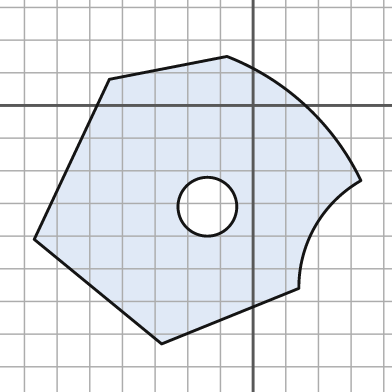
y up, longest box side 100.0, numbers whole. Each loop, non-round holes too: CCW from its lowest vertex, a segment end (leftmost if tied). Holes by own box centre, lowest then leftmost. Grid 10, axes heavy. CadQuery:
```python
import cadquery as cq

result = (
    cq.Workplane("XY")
    .moveTo(-28.0, -73.0)
    .lineTo(14.0, -56.0)
    .threePointArc((19.0, -37.0), (33.0, -23.0))
    .threePointArc((16.0, 0.0), (-8.0, 15.0))
    .lineTo(-44.0, 8.0)
    .lineTo(-67.0, -41.0)
    .close()
    .moveTo(-14.0, -31.0)
    .circle(9.0)
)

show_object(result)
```